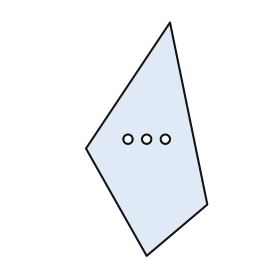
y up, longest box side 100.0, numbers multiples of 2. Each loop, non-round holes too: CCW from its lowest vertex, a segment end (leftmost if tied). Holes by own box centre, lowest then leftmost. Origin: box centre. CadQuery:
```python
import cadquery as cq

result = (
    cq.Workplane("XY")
    .moveTo(0.0, -50.0)
    .lineTo(26.0, -28.0)
    .lineTo(10.0, 50.0)
    .lineTo(-26.0, -4.0)
    .close()
    .moveTo(-8.0, 0.0)
    .circle(2.0)
    .moveTo(0.0, 0.0)
    .circle(2.0)
    .moveTo(8.0, 0.0)
    .circle(2.0)
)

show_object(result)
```